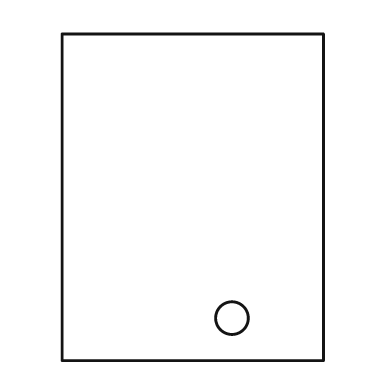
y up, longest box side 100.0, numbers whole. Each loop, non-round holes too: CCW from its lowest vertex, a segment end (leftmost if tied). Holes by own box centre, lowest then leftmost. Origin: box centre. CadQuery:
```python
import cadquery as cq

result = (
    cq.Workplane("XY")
    .moveTo(-40.0, -50.0)
    .lineTo(40.0, -50.0)
    .lineTo(40.0, 50.0)
    .lineTo(-40.0, 50.0)
    .close()
    .moveTo(12.0, -37.0)
    .circle(5.0)
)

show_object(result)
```